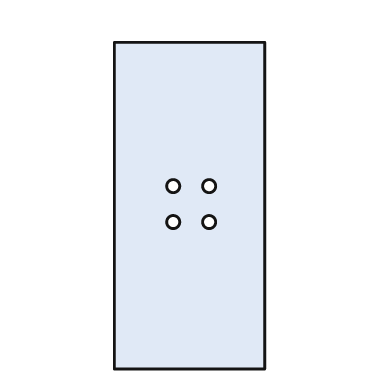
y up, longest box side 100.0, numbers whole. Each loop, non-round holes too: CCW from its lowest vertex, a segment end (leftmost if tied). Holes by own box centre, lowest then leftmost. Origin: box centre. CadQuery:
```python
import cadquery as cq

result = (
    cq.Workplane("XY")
    .moveTo(-23.0, -50.0)
    .lineTo(23.0, -50.0)
    .lineTo(23.0, 50.0)
    .lineTo(-23.0, 50.0)
    .close()
    .moveTo(-5.0, -5.0)
    .circle(2.0)
    .moveTo(6.0, -5.0)
    .circle(2.0)
    .moveTo(-5.0, 6.0)
    .circle(2.0)
    .moveTo(6.0, 6.0)
    .circle(2.0)
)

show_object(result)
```